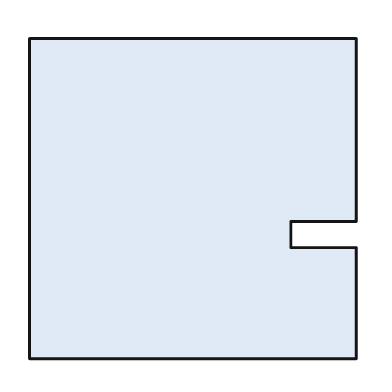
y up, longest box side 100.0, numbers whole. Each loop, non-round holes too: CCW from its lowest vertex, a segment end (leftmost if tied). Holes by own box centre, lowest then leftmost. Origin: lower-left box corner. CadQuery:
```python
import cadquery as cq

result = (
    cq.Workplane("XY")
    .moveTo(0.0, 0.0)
    .lineTo(100.0, 0.0)
    .lineTo(100.0, 34.0)
    .lineTo(80.0, 34.0)
    .lineTo(80.0, 42.0)
    .lineTo(100.0, 42.0)
    .lineTo(100.0, 98.0)
    .lineTo(0.0, 98.0)
    .close()
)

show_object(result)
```